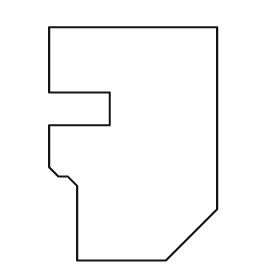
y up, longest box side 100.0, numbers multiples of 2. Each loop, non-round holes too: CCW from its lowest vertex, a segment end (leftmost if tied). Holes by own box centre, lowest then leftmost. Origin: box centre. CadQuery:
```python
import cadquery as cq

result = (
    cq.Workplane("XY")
    .moveTo(-24.0, -50.0)
    .lineTo(14.0, -50.0)
    .lineTo(36.0, -28.0)
    .lineTo(36.0, 50.0)
    .lineTo(-36.0, 50.0)
    .lineTo(-36.0, 22.0)
    .lineTo(-10.0, 22.0)
    .lineTo(-10.0, 8.0)
    .lineTo(-36.0, 8.0)
    .lineTo(-36.0, -10.0)
    .lineTo(-32.0, -14.0)
    .lineTo(-28.0, -14.0)
    .lineTo(-24.0, -18.0)
    .close()
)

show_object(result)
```